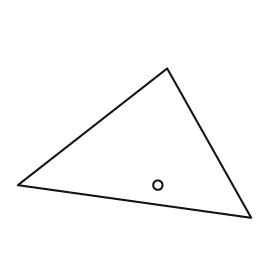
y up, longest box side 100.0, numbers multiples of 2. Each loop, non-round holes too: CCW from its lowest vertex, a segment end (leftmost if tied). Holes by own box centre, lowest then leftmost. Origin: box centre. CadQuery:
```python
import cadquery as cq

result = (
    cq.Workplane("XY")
    .moveTo(50.0, -32.0)
    .lineTo(14.0, 32.0)
    .lineTo(-50.0, -18.0)
    .close()
    .moveTo(10.0, -18.0)
    .circle(2.0)
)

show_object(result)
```